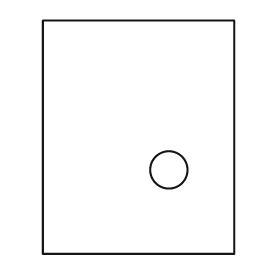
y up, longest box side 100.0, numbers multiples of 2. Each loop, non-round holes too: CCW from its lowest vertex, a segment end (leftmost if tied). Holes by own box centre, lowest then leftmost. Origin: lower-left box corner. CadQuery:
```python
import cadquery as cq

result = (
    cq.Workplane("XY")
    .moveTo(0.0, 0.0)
    .lineTo(82.0, 0.0)
    .lineTo(82.0, 100.0)
    .lineTo(0.0, 100.0)
    .close()
    .moveTo(54.0, 36.0)
    .circle(8.0)
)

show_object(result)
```